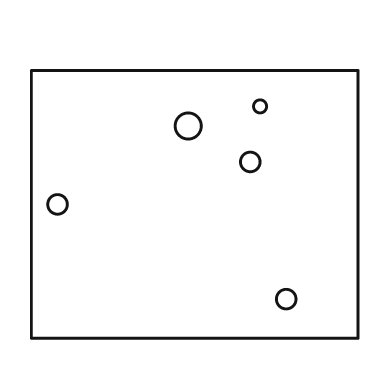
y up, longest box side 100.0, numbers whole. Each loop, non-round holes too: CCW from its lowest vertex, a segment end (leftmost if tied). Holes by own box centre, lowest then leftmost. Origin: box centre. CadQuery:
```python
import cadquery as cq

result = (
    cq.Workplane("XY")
    .moveTo(-50.0, -41.0)
    .lineTo(50.0, -41.0)
    .lineTo(50.0, 41.0)
    .lineTo(-50.0, 41.0)
    .close()
    .moveTo(28.0, -29.0)
    .circle(3.0)
    .moveTo(-42.0, 0.0)
    .circle(3.0)
    .moveTo(17.0, 13.0)
    .circle(3.0)
    .moveTo(-2.0, 24.0)
    .circle(4.0)
    .moveTo(20.0, 30.0)
    .circle(2.0)
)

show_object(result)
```